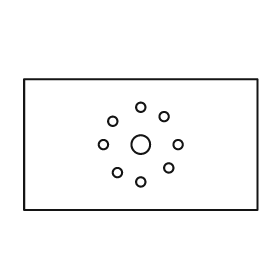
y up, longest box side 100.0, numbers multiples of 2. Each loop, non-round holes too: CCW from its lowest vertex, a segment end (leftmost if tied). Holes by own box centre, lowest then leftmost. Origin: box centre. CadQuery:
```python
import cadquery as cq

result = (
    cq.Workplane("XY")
    .moveTo(-50.0, -28.0)
    .lineTo(50.0, -28.0)
    .lineTo(50.0, 28.0)
    .lineTo(-50.0, 28.0)
    .close()
    .moveTo(0.0, -16.0)
    .circle(2.0)
    .moveTo(-10.0, -12.0)
    .circle(2.0)
    .moveTo(12.0, -10.0)
    .circle(2.0)
    .moveTo(-16.0, 0.0)
    .circle(2.0)
    .moveTo(0.0, 0.0)
    .circle(4.0)
    .moveTo(16.0, 0.0)
    .circle(2.0)
    .moveTo(-12.0, 10.0)
    .circle(2.0)
    .moveTo(10.0, 12.0)
    .circle(2.0)
    .moveTo(0.0, 16.0)
    .circle(2.0)
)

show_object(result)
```